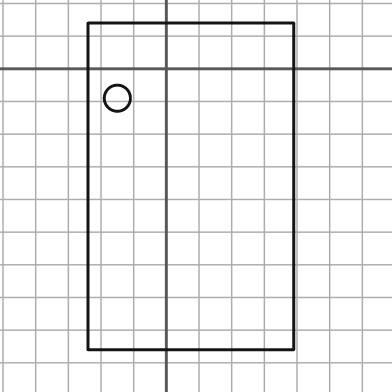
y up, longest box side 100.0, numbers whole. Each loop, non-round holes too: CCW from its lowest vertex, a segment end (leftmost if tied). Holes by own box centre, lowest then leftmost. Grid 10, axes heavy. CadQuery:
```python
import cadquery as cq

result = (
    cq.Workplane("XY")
    .moveTo(-24.0, -86.0)
    .lineTo(39.0, -86.0)
    .lineTo(39.0, 14.0)
    .lineTo(-24.0, 14.0)
    .close()
    .moveTo(-15.0, -9.0)
    .circle(4.0)
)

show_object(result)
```